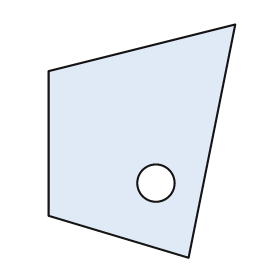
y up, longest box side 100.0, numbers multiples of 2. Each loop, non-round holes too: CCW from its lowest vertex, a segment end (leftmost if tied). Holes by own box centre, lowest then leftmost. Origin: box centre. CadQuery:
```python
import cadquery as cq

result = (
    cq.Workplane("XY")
    .moveTo(20.0, -50.0)
    .lineTo(40.0, 50.0)
    .lineTo(-40.0, 30.0)
    .lineTo(-40.0, -32.0)
    .close()
    .moveTo(6.0, -18.0)
    .circle(8.0)
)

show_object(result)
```